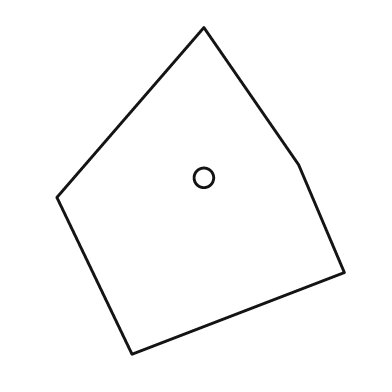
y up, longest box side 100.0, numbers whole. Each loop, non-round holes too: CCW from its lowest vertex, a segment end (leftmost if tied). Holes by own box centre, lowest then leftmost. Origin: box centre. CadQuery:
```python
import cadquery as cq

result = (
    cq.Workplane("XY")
    .moveTo(-21.0, -50.0)
    .lineTo(44.0, -25.0)
    .lineTo(30.0, 8.0)
    .lineTo(1.0, 50.0)
    .lineTo(-44.0, -2.0)
    .close()
    .moveTo(1.0, 4.0)
    .circle(3.0)
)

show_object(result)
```